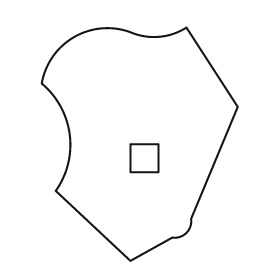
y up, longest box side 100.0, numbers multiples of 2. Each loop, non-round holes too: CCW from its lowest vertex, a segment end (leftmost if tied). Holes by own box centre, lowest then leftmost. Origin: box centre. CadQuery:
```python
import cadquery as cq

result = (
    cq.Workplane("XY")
    .moveTo(-4.0, -50.0)
    .lineTo(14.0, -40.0)
    .threePointArc((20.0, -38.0), (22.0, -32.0))
    .lineTo(42.0, 16.0)
    .lineTo(20.0, 50.0)
    .threePointArc((8.0, 46.0), (-4.0, 48.0))
    .threePointArc((-28.0, 46.0), (-42.0, 26.0))
    .threePointArc((-30.0, 4.0), (-36.0, -20.0))
    .close()
    .moveTo(-4.0, -12.0)
    .lineTo(8.0, -12.0)
    .lineTo(8.0, 0.0)
    .lineTo(-4.0, 0.0)
    .close()
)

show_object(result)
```